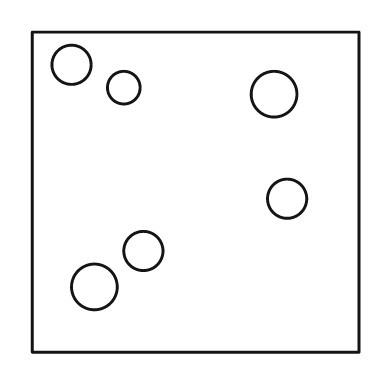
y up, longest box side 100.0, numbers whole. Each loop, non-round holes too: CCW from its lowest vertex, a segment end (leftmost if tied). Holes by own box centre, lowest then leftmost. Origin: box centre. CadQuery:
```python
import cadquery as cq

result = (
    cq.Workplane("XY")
    .moveTo(-50.0, -49.0)
    .lineTo(50.0, -49.0)
    .lineTo(50.0, 49.0)
    .lineTo(-50.0, 49.0)
    .close()
    .moveTo(-31.0, -29.0)
    .circle(7.0)
    .moveTo(-16.0, -18.0)
    .circle(6.0)
    .moveTo(28.0, -2.0)
    .circle(6.0)
    .moveTo(24.0, 30.0)
    .circle(7.0)
    .moveTo(-22.0, 32.0)
    .circle(5.0)
    .moveTo(-38.0, 39.0)
    .circle(6.0)
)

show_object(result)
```